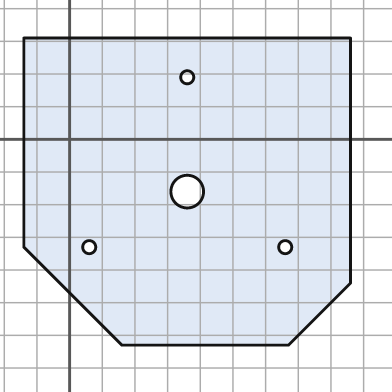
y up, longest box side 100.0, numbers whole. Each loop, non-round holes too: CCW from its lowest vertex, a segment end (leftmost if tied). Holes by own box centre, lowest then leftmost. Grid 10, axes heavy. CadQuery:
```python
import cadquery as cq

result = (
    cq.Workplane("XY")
    .moveTo(16.0, -63.0)
    .lineTo(67.0, -63.0)
    .lineTo(86.0, -44.0)
    .lineTo(86.0, 31.0)
    .lineTo(-14.0, 31.0)
    .lineTo(-14.0, -33.0)
    .close()
    .moveTo(6.0, -33.0)
    .circle(2.0)
    .moveTo(66.0, -33.0)
    .circle(2.0)
    .moveTo(36.0, -16.0)
    .circle(5.0)
    .moveTo(36.0, 19.0)
    .circle(2.0)
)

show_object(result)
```